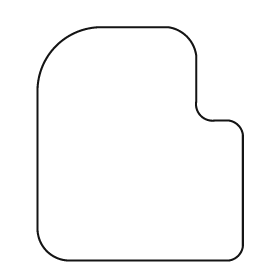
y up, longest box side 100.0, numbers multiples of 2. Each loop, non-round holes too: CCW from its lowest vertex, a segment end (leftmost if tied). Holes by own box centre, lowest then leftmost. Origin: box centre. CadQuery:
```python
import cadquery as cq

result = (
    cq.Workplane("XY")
    .moveTo(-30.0, -50.0)
    .lineTo(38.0, -50.0)
    .threePointArc((42.0, -48.0), (44.0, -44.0))
    .lineTo(44.0, 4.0)
    .threePointArc((42.0, 8.0), (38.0, 10.0))
    .lineTo(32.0, 10.0)
    .threePointArc((26.0, 12.0), (24.0, 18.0))
    .lineTo(24.0, 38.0)
    .threePointArc((20.0, 46.0), (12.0, 50.0))
    .lineTo(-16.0, 50.0)
    .threePointArc((-36.0, 42.0), (-44.0, 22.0))
    .lineTo(-44.0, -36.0)
    .threePointArc((-40.0, -46.0), (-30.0, -50.0))
    .close()
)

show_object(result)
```